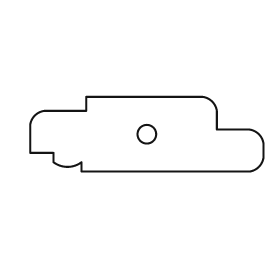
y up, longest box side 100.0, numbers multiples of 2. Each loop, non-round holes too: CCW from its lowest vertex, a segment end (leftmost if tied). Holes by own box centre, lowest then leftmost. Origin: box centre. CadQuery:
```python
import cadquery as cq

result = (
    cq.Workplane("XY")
    .moveTo(-28.0, -16.0)
    .lineTo(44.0, -16.0)
    .threePointArc((48.0, -14.0), (50.0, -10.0))
    .lineTo(50.0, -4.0)
    .threePointArc((48.0, 0.0), (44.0, 2.0))
    .lineTo(30.0, 2.0)
    .lineTo(30.0, 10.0)
    .threePointArc((28.0, 14.0), (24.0, 16.0))
    .lineTo(-26.0, 16.0)
    .lineTo(-26.0, 10.0)
    .lineTo(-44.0, 10.0)
    .threePointArc((-48.0, 8.0), (-50.0, 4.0))
    .lineTo(-50.0, -8.0)
    .lineTo(-40.0, -8.0)
    .lineTo(-40.0, -12.0)
    .threePointArc((-34.0, -14.0), (-28.0, -12.0))
    .close()
    .moveTo(0.0, 0.0)
    .circle(4.0)
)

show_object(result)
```